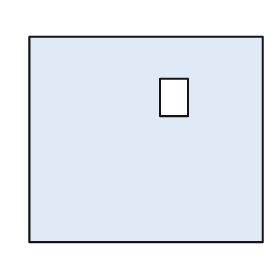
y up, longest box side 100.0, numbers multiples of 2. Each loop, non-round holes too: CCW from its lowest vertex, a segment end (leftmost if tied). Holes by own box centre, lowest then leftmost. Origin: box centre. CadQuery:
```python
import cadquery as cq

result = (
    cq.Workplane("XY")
    .moveTo(-50.0, -44.0)
    .lineTo(50.0, -44.0)
    .lineTo(50.0, 44.0)
    .lineTo(-50.0, 44.0)
    .close()
    .moveTo(6.0, 10.0)
    .lineTo(18.0, 10.0)
    .lineTo(18.0, 26.0)
    .lineTo(6.0, 26.0)
    .close()
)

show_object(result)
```